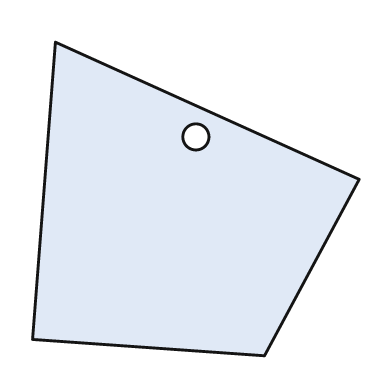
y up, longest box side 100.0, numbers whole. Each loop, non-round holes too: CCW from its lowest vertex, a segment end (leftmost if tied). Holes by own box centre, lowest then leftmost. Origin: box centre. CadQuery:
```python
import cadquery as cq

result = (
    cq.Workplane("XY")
    .moveTo(21.0, -48.0)
    .lineTo(50.0, 6.0)
    .lineTo(-43.0, 48.0)
    .lineTo(-50.0, -43.0)
    .close()
    .moveTo(0.0, 19.0)
    .circle(4.0)
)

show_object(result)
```